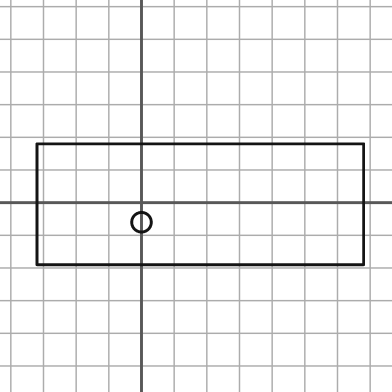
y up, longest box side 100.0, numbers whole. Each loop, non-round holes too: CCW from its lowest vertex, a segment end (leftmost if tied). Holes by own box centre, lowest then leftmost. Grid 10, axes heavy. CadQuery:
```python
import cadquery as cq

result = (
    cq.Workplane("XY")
    .moveTo(-32.0, -19.0)
    .lineTo(68.0, -19.0)
    .lineTo(68.0, 18.0)
    .lineTo(-32.0, 18.0)
    .close()
    .moveTo(0.0, -6.0)
    .circle(3.0)
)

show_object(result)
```